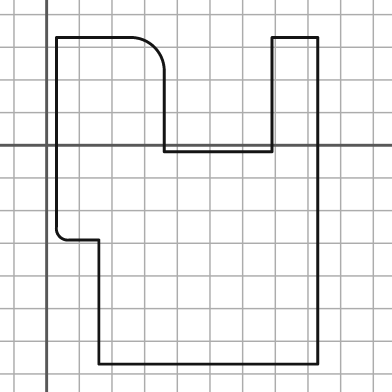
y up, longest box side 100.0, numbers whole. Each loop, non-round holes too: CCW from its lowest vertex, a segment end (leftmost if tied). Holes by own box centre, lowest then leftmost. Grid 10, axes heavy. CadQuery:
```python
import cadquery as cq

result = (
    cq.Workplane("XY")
    .moveTo(16.0, -67.0)
    .lineTo(83.0, -67.0)
    .lineTo(83.0, 33.0)
    .lineTo(69.0, 33.0)
    .lineTo(69.0, -2.0)
    .lineTo(36.0, -2.0)
    .lineTo(36.0, 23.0)
    .threePointArc((33.0, 30.0), (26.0, 33.0))
    .lineTo(3.0, 33.0)
    .lineTo(3.0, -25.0)
    .threePointArc((4.0, -28.0), (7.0, -29.0))
    .lineTo(16.0, -29.0)
    .close()
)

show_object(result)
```